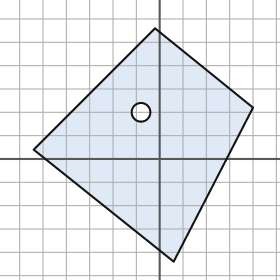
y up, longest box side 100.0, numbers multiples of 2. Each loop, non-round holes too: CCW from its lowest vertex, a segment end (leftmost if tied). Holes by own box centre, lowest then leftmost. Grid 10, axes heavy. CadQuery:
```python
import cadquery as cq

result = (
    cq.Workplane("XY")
    .moveTo(6.0, -44.0)
    .lineTo(40.0, 22.0)
    .lineTo(-2.0, 56.0)
    .lineTo(-54.0, 4.0)
    .close()
    .moveTo(-8.0, 20.0)
    .circle(4.0)
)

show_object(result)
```